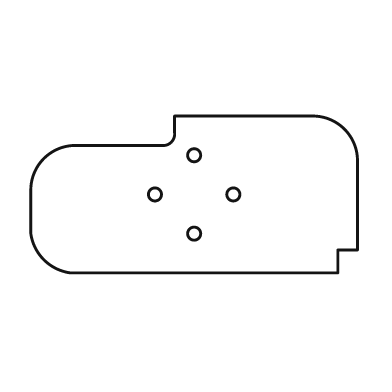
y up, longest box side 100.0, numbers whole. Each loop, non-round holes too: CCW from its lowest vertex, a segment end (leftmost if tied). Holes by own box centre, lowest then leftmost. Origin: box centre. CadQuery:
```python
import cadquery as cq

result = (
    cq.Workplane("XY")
    .moveTo(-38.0, -24.0)
    .lineTo(44.0, -24.0)
    .lineTo(44.0, -17.0)
    .lineTo(50.0, -17.0)
    .lineTo(50.0, 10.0)
    .threePointArc((46.0, 20.0), (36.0, 24.0))
    .lineTo(-6.0, 24.0)
    .lineTo(-6.0, 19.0)
    .threePointArc((-7.0, 16.0), (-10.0, 15.0))
    .lineTo(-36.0, 15.0)
    .threePointArc((-46.0, 11.0), (-50.0, 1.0))
    .lineTo(-50.0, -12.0)
    .threePointArc((-46.0, -20.0), (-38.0, -24.0))
    .close()
    .moveTo(0.0, -12.0)
    .circle(2.0)
    .moveTo(-12.0, 0.0)
    .circle(2.0)
    .moveTo(12.0, 0.0)
    .circle(2.0)
    .moveTo(0.0, 12.0)
    .circle(2.0)
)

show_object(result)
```